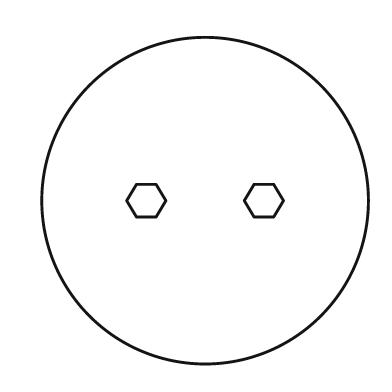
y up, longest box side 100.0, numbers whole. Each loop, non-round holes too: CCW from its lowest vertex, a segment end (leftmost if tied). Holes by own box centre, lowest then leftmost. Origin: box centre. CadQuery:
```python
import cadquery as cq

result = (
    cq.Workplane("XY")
    .moveTo(0.0, 0.0)
    .circle(50.0)
    .moveTo(-21.0, -5.0)
    .lineTo(-15.0, -5.0)
    .lineTo(-12.0, 0.0)
    .lineTo(-15.0, 5.0)
    .lineTo(-21.0, 5.0)
    .lineTo(-24.0, 0.0)
    .close()
    .moveTo(15.0, -5.0)
    .lineTo(21.0, -5.0)
    .lineTo(24.0, 0.0)
    .lineTo(21.0, 5.0)
    .lineTo(15.0, 5.0)
    .lineTo(12.0, 0.0)
    .close()
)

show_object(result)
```